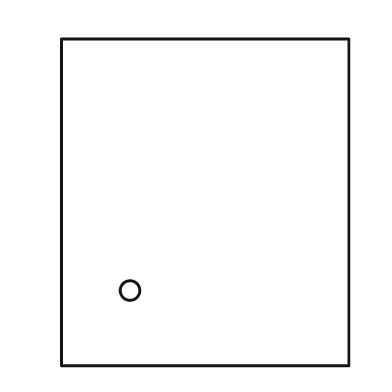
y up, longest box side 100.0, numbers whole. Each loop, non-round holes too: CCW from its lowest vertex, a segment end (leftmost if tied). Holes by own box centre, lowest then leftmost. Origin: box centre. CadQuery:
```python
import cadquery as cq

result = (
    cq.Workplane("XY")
    .moveTo(-44.0, -50.0)
    .lineTo(44.0, -50.0)
    .lineTo(44.0, 50.0)
    .lineTo(-44.0, 50.0)
    .close()
    .moveTo(-23.0, -27.0)
    .circle(3.0)
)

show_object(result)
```